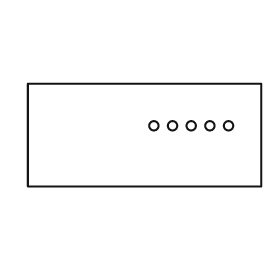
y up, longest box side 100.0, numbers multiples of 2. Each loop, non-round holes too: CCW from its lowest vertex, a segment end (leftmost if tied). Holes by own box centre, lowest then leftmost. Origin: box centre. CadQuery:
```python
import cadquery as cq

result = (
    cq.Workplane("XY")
    .moveTo(-50.0, -22.0)
    .lineTo(50.0, -22.0)
    .lineTo(50.0, 22.0)
    .lineTo(-50.0, 22.0)
    .close()
    .moveTo(4.0, 4.0)
    .circle(2.0)
    .moveTo(12.0, 4.0)
    .circle(2.0)
    .moveTo(20.0, 4.0)
    .circle(2.0)
    .moveTo(28.0, 4.0)
    .circle(2.0)
    .moveTo(36.0, 4.0)
    .circle(2.0)
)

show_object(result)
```